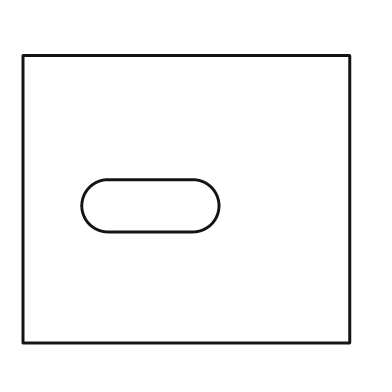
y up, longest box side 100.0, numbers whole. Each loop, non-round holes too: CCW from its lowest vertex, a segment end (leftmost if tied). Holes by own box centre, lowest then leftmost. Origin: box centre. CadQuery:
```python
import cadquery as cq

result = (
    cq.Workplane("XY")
    .moveTo(-50.0, -44.0)
    .lineTo(50.0, -44.0)
    .lineTo(50.0, 44.0)
    .lineTo(-50.0, 44.0)
    .close()
    .moveTo(-24.0, -10.0)
    .lineTo(2.0, -10.0)
    .threePointArc((10.0, -2.0), (2.0, 6.0))
    .lineTo(-24.0, 6.0)
    .threePointArc((-32.0, -2.0), (-24.0, -10.0))
    .close()
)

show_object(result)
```